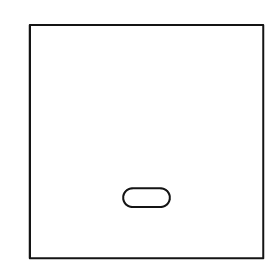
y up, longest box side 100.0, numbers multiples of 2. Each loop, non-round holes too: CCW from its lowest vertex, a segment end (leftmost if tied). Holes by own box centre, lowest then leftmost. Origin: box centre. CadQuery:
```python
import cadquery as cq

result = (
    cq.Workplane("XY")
    .moveTo(-50.0, -50.0)
    .lineTo(50.0, -50.0)
    .lineTo(50.0, 50.0)
    .lineTo(-50.0, 50.0)
    .close()
    .moveTo(-6.0, -28.0)
    .lineTo(6.0, -28.0)
    .threePointArc((10.0, -24.0), (6.0, -20.0))
    .lineTo(-6.0, -20.0)
    .threePointArc((-10.0, -24.0), (-6.0, -28.0))
    .close()
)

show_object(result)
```